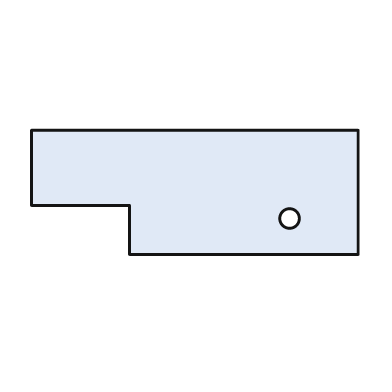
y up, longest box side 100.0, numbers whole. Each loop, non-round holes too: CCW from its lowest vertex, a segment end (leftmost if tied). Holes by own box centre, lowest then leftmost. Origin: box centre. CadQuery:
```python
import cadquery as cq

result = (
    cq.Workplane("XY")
    .moveTo(-20.0, -19.0)
    .lineTo(50.0, -19.0)
    .lineTo(50.0, 19.0)
    .lineTo(-50.0, 19.0)
    .lineTo(-50.0, -4.0)
    .lineTo(-20.0, -4.0)
    .close()
    .moveTo(29.0, -8.0)
    .circle(3.0)
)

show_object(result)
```